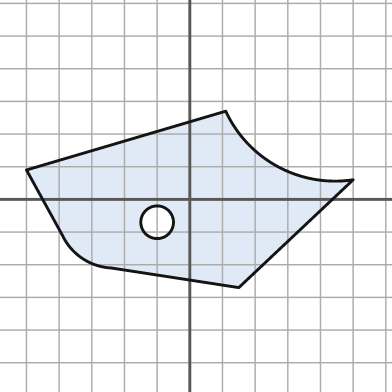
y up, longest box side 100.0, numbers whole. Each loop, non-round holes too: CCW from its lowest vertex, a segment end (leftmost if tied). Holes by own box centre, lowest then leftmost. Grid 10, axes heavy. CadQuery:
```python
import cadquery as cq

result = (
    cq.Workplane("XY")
    .moveTo(15.0, -27.0)
    .lineTo(50.0, 6.0)
    .threePointArc((27.0, 10.0), (11.0, 27.0))
    .lineTo(-50.0, 9.0)
    .lineTo(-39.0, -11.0)
    .threePointArc((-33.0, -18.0), (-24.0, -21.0))
    .close()
    .moveTo(-10.0, -7.0)
    .circle(5.0)
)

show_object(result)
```